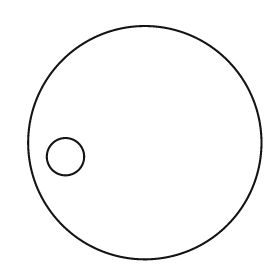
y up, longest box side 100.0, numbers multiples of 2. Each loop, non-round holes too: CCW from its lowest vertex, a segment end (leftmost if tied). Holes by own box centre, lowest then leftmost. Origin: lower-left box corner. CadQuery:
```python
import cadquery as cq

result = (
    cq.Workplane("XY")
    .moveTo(50.0, 50.0)
    .circle(50.0)
    .moveTo(16.0, 44.0)
    .circle(8.0)
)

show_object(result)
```